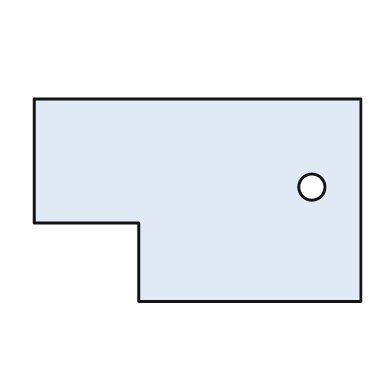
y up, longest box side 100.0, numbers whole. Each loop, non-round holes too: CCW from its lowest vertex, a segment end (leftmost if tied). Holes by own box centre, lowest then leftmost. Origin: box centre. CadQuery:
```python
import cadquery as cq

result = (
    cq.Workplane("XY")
    .moveTo(-18.0, -31.0)
    .lineTo(50.0, -31.0)
    .lineTo(50.0, 31.0)
    .lineTo(-50.0, 31.0)
    .lineTo(-50.0, -7.0)
    .lineTo(-18.0, -7.0)
    .close()
    .moveTo(35.0, 4.0)
    .circle(4.0)
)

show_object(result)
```